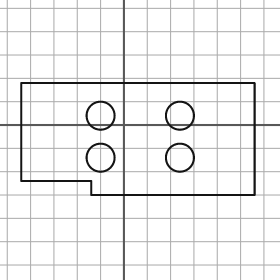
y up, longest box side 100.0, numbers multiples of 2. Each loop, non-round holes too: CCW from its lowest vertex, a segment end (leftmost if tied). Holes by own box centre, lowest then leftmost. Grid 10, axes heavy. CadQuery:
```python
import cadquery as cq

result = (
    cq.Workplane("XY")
    .moveTo(-14.0, -30.0)
    .lineTo(56.0, -30.0)
    .lineTo(56.0, 18.0)
    .lineTo(-44.0, 18.0)
    .lineTo(-44.0, -24.0)
    .lineTo(-14.0, -24.0)
    .close()
    .moveTo(-10.0, -14.0)
    .circle(6.0)
    .moveTo(24.0, -14.0)
    .circle(6.0)
    .moveTo(-10.0, 4.0)
    .circle(6.0)
    .moveTo(24.0, 4.0)
    .circle(6.0)
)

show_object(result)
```